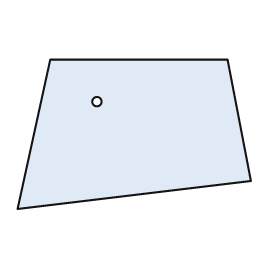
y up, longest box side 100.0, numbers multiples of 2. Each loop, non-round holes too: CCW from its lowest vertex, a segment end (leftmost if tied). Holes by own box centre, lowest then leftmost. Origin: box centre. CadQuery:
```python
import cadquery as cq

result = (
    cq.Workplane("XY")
    .moveTo(-50.0, -32.0)
    .lineTo(50.0, -20.0)
    .lineTo(40.0, 32.0)
    .lineTo(-36.0, 32.0)
    .close()
    .moveTo(-16.0, 14.0)
    .circle(2.0)
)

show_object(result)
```